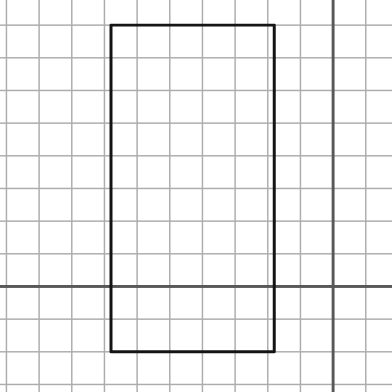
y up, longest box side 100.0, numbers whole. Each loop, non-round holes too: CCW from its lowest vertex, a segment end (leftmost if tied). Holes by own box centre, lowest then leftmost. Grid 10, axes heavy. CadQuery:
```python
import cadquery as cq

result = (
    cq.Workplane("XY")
    .moveTo(-68.0, -20.0)
    .lineTo(-18.0, -20.0)
    .lineTo(-18.0, 80.0)
    .lineTo(-68.0, 80.0)
    .close()
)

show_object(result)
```